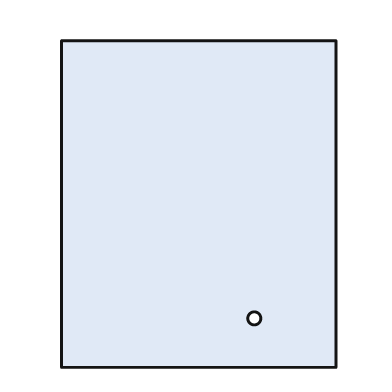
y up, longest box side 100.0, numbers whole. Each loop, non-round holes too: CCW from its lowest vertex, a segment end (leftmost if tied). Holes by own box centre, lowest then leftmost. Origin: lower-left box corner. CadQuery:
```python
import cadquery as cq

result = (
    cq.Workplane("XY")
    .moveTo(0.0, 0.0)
    .lineTo(84.0, 0.0)
    .lineTo(84.0, 100.0)
    .lineTo(0.0, 100.0)
    .close()
    .moveTo(59.0, 15.0)
    .circle(2.0)
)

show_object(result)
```